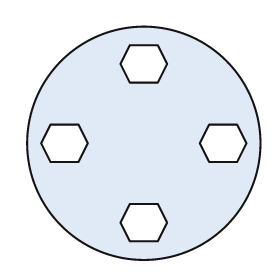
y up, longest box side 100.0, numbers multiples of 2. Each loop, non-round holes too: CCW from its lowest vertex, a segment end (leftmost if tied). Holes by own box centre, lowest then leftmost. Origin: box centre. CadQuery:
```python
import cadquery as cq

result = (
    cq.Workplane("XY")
    .moveTo(0.0, 0.0)
    .circle(50.0)
    .moveTo(-6.0, -42.0)
    .lineTo(6.0, -42.0)
    .lineTo(10.0, -34.0)
    .lineTo(6.0, -26.0)
    .lineTo(-6.0, -26.0)
    .lineTo(-10.0, -34.0)
    .close()
    .moveTo(-40.0, -8.0)
    .lineTo(-28.0, -8.0)
    .lineTo(-24.0, 0.0)
    .lineTo(-28.0, 8.0)
    .lineTo(-40.0, 8.0)
    .lineTo(-44.0, 0.0)
    .close()
    .moveTo(28.0, -8.0)
    .lineTo(40.0, -8.0)
    .lineTo(44.0, 0.0)
    .lineTo(40.0, 8.0)
    .lineTo(28.0, 8.0)
    .lineTo(24.0, 0.0)
    .close()
    .moveTo(-6.0, 26.0)
    .lineTo(6.0, 26.0)
    .lineTo(10.0, 34.0)
    .lineTo(6.0, 42.0)
    .lineTo(-6.0, 42.0)
    .lineTo(-10.0, 34.0)
    .close()
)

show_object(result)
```